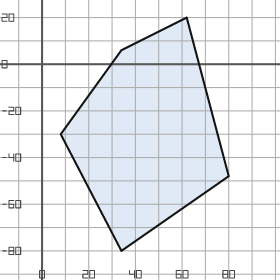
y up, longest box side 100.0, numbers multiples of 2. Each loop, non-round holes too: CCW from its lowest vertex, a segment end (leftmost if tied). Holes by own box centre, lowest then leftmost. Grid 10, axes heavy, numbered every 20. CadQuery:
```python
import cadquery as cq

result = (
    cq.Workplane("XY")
    .moveTo(34.0, -80.0)
    .lineTo(80.0, -48.0)
    .lineTo(62.0, 20.0)
    .lineTo(34.0, 6.0)
    .lineTo(8.0, -30.0)
    .close()
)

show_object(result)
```